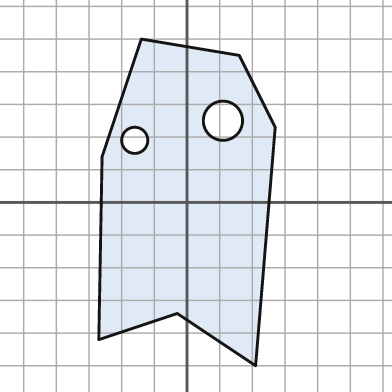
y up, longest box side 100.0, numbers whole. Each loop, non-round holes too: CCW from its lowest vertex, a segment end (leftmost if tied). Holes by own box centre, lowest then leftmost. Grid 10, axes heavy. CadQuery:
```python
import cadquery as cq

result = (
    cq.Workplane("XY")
    .moveTo(21.0, -50.0)
    .lineTo(27.0, 23.0)
    .lineTo(16.0, 45.0)
    .lineTo(-14.0, 50.0)
    .lineTo(-26.0, 14.0)
    .lineTo(-27.0, -42.0)
    .lineTo(-3.0, -34.0)
    .close()
    .moveTo(-16.0, 19.0)
    .circle(4.0)
    .moveTo(11.0, 25.0)
    .circle(6.0)
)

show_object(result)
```